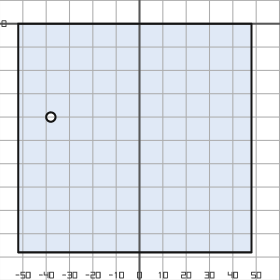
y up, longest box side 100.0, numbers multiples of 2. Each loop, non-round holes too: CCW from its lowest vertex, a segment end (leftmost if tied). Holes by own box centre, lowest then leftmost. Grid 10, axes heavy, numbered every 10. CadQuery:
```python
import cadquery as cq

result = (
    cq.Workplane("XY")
    .moveTo(-52.0, -98.0)
    .lineTo(48.0, -98.0)
    .lineTo(48.0, 0.0)
    .lineTo(-52.0, 0.0)
    .close()
    .moveTo(-38.0, -40.0)
    .circle(2.0)
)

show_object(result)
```